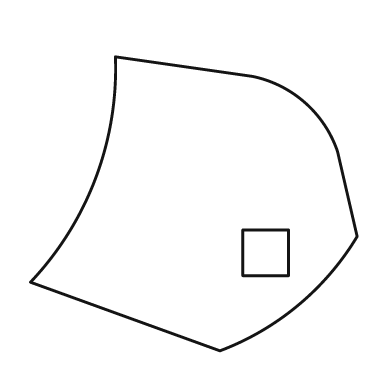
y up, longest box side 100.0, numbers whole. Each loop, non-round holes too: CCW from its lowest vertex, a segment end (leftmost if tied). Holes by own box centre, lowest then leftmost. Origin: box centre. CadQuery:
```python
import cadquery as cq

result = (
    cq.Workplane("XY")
    .moveTo(8.0, -45.0)
    .threePointArc((32.0, -31.0), (50.0, -10.0))
    .lineTo(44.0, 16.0)
    .threePointArc((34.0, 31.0), (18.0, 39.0))
    .lineTo(-24.0, 45.0)
    .threePointArc((-30.0, 8.0), (-50.0, -24.0))
    .close()
    .moveTo(15.0, -22.0)
    .lineTo(29.0, -22.0)
    .lineTo(29.0, -8.0)
    .lineTo(15.0, -8.0)
    .close()
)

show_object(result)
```